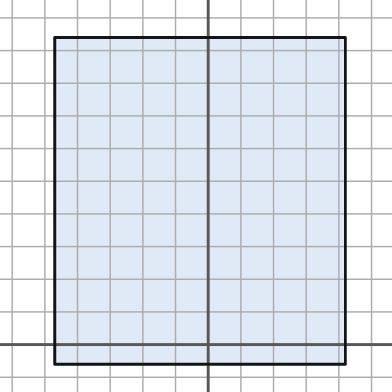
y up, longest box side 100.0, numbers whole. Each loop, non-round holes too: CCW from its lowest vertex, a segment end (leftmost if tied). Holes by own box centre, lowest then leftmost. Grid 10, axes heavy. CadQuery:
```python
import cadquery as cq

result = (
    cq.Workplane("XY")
    .moveTo(-47.0, -6.0)
    .lineTo(42.0, -6.0)
    .lineTo(42.0, 94.0)
    .lineTo(-47.0, 94.0)
    .close()
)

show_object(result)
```